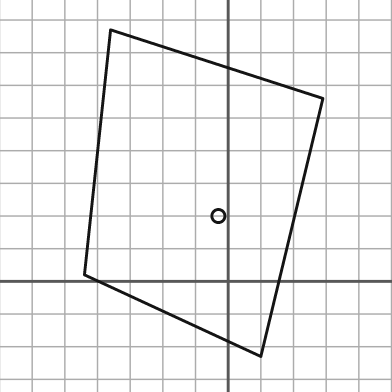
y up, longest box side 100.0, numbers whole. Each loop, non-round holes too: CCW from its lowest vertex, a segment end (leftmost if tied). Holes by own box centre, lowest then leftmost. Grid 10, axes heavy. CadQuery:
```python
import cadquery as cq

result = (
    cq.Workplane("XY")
    .moveTo(10.0, -23.0)
    .lineTo(29.0, 56.0)
    .lineTo(-36.0, 77.0)
    .lineTo(-44.0, 2.0)
    .close()
    .moveTo(-3.0, 20.0)
    .circle(2.0)
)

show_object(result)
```